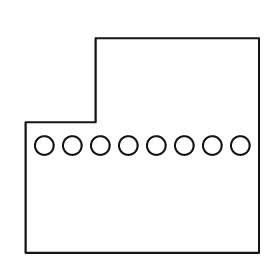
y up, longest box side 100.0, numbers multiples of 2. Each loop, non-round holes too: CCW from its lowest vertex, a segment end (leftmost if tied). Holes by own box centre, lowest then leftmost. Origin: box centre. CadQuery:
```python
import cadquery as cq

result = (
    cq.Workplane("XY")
    .moveTo(-50.0, -46.0)
    .lineTo(50.0, -46.0)
    .lineTo(50.0, 46.0)
    .lineTo(-20.0, 46.0)
    .lineTo(-20.0, 10.0)
    .lineTo(-50.0, 10.0)
    .close()
    .moveTo(-42.0, 0.0)
    .circle(4.0)
    .moveTo(-30.0, 0.0)
    .circle(4.0)
    .moveTo(-18.0, 0.0)
    .circle(4.0)
    .moveTo(-6.0, 0.0)
    .circle(4.0)
    .moveTo(6.0, 0.0)
    .circle(4.0)
    .moveTo(18.0, 0.0)
    .circle(4.0)
    .moveTo(30.0, 0.0)
    .circle(4.0)
    .moveTo(42.0, 0.0)
    .circle(4.0)
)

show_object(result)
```